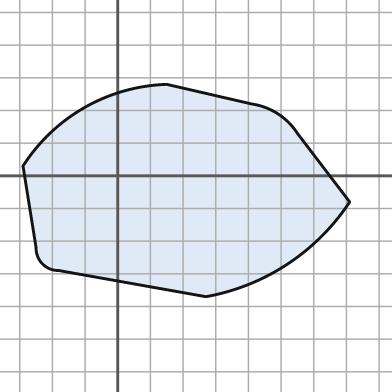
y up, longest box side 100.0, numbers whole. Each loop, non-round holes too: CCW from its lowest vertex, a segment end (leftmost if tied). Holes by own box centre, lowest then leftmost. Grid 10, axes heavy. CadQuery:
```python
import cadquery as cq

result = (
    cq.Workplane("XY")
    .moveTo(27.0, -37.0)
    .threePointArc((52.0, -27.0), (71.0, -8.0))
    .lineTo(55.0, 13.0)
    .threePointArc((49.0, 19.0), (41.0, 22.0))
    .lineTo(15.0, 28.0)
    .threePointArc((-10.0, 21.0), (-29.0, 3.0))
    .lineTo(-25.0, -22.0)
    .threePointArc((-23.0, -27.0), (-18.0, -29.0))
    .close()
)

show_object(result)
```